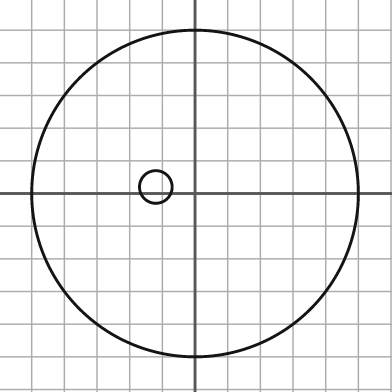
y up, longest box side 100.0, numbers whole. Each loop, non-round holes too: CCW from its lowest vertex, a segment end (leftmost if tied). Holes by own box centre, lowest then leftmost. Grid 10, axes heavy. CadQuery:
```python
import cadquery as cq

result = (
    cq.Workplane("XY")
    .moveTo(0.0, 0.0)
    .circle(50.0)
    .moveTo(-12.0, 2.0)
    .circle(5.0)
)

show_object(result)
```